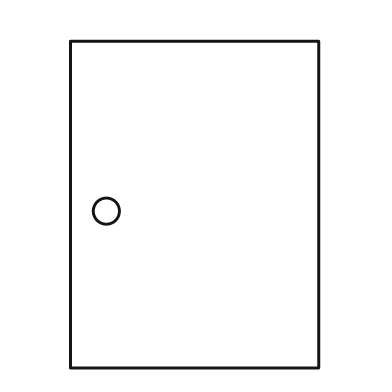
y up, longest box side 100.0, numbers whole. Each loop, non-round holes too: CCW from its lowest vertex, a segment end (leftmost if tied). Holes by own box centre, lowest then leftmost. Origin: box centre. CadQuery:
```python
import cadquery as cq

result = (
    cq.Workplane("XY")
    .moveTo(-38.0, -50.0)
    .lineTo(38.0, -50.0)
    .lineTo(38.0, 50.0)
    .lineTo(-38.0, 50.0)
    .close()
    .moveTo(-27.0, -2.0)
    .circle(4.0)
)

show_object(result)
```